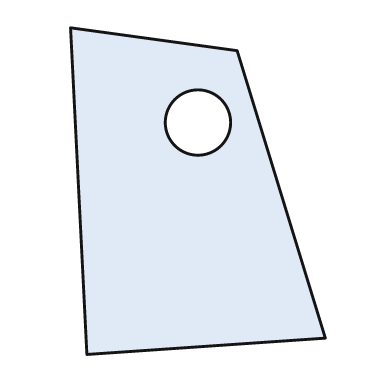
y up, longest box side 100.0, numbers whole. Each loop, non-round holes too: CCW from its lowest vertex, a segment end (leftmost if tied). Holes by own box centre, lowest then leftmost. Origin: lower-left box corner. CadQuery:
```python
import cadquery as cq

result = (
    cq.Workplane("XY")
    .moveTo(5.0, 0.0)
    .lineTo(78.0, 5.0)
    .lineTo(51.0, 93.0)
    .lineTo(0.0, 100.0)
    .close()
    .moveTo(39.0, 71.0)
    .circle(10.0)
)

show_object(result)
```